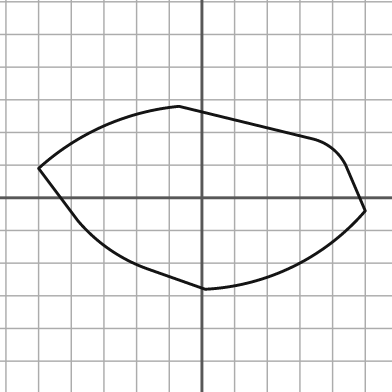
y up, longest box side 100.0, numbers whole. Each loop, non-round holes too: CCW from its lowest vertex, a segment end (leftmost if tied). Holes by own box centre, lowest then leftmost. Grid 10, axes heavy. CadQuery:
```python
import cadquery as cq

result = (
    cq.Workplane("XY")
    .moveTo(1.0, -28.0)
    .threePointArc((28.0, -21.0), (50.0, -4.0))
    .lineTo(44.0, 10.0)
    .threePointArc((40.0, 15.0), (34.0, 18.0))
    .lineTo(-7.0, 28.0)
    .threePointArc((-30.0, 22.0), (-50.0, 9.0))
    .lineTo(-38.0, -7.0)
    .threePointArc((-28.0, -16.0), (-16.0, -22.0))
    .close()
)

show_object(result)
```